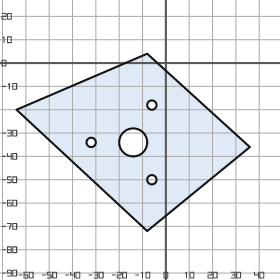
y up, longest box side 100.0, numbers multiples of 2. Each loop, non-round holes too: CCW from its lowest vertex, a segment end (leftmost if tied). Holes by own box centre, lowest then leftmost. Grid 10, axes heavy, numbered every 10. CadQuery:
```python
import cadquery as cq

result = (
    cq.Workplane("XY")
    .moveTo(-8.0, -72.0)
    .lineTo(36.0, -36.0)
    .lineTo(-8.0, 4.0)
    .lineTo(-64.0, -20.0)
    .close()
    .moveTo(-6.0, -50.0)
    .circle(2.0)
    .moveTo(-32.0, -34.0)
    .circle(2.0)
    .moveTo(-14.0, -34.0)
    .circle(6.0)
    .moveTo(-6.0, -18.0)
    .circle(2.0)
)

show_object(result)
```